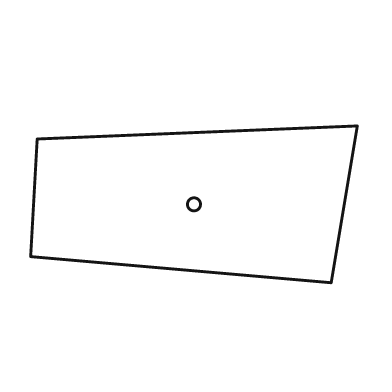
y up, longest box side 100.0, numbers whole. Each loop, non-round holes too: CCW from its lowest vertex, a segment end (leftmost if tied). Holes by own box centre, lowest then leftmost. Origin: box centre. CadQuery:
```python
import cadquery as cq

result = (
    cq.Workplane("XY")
    .moveTo(42.0, -24.0)
    .lineTo(50.0, 24.0)
    .lineTo(-48.0, 20.0)
    .lineTo(-50.0, -16.0)
    .close()
    .moveTo(0.0, 0.0)
    .circle(2.0)
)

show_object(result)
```